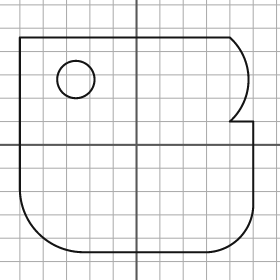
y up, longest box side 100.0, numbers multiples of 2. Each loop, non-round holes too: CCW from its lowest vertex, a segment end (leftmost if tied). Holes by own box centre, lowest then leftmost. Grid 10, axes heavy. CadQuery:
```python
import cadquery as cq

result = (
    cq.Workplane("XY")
    .moveTo(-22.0, -46.0)
    .lineTo(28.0, -46.0)
    .threePointArc((44.0, -40.0), (50.0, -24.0))
    .lineTo(50.0, 10.0)
    .lineTo(40.0, 10.0)
    .threePointArc((48.0, 28.0), (40.0, 46.0))
    .lineTo(-50.0, 46.0)
    .lineTo(-50.0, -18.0)
    .threePointArc((-42.0, -38.0), (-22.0, -46.0))
    .close()
    .moveTo(-26.0, 28.0)
    .circle(8.0)
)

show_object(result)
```